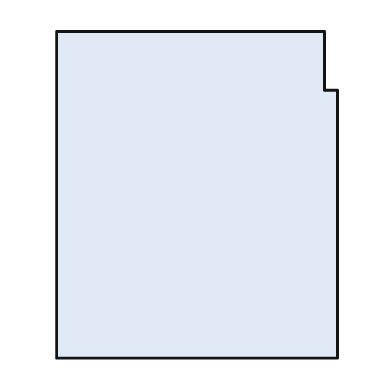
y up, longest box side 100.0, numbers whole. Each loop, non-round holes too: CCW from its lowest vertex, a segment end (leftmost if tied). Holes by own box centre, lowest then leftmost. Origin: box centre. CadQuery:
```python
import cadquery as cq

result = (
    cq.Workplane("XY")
    .moveTo(-43.0, -50.0)
    .lineTo(43.0, -50.0)
    .lineTo(43.0, 32.0)
    .lineTo(39.0, 32.0)
    .lineTo(39.0, 50.0)
    .lineTo(-43.0, 50.0)
    .close()
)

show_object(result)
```